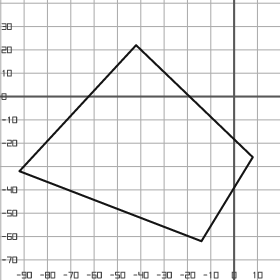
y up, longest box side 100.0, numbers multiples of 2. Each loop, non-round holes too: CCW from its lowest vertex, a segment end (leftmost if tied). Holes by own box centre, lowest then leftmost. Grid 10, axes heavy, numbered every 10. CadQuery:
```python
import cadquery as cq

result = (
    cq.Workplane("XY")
    .moveTo(-14.0, -62.0)
    .lineTo(8.0, -26.0)
    .lineTo(-42.0, 22.0)
    .lineTo(-92.0, -32.0)
    .close()
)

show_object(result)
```